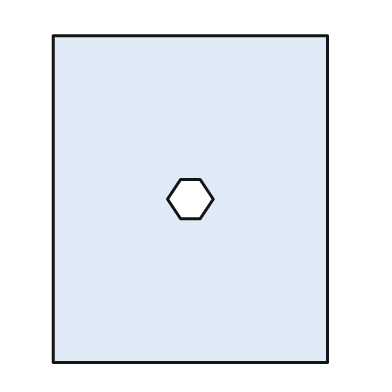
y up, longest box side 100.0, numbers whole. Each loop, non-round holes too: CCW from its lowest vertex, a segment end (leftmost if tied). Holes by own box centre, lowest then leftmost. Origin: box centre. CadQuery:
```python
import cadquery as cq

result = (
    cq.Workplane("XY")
    .moveTo(-42.0, -50.0)
    .lineTo(42.0, -50.0)
    .lineTo(42.0, 50.0)
    .lineTo(-42.0, 50.0)
    .close()
    .moveTo(-3.0, -6.0)
    .lineTo(3.0, -6.0)
    .lineTo(7.0, 0.0)
    .lineTo(3.0, 6.0)
    .lineTo(-3.0, 6.0)
    .lineTo(-7.0, 0.0)
    .close()
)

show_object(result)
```